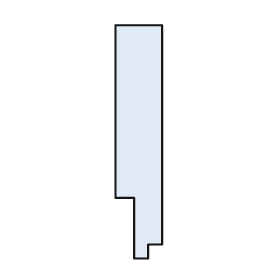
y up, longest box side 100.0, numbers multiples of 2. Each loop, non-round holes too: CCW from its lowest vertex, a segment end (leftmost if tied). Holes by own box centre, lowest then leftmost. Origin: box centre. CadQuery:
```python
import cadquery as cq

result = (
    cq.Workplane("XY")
    .moveTo(-2.0, -50.0)
    .lineTo(4.0, -50.0)
    .lineTo(4.0, -44.0)
    .lineTo(10.0, -44.0)
    .lineTo(10.0, 50.0)
    .lineTo(-10.0, 50.0)
    .lineTo(-10.0, -24.0)
    .lineTo(-2.0, -24.0)
    .close()
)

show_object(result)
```